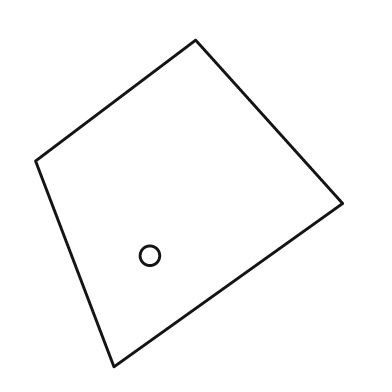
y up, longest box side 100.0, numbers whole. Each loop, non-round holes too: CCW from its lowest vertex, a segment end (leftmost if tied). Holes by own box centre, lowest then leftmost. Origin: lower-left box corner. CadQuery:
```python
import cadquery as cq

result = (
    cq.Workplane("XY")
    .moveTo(24.0, 0.0)
    .lineTo(94.0, 50.0)
    .lineTo(49.0, 100.0)
    .lineTo(0.0, 63.0)
    .close()
    .moveTo(35.0, 34.0)
    .circle(3.0)
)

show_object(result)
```